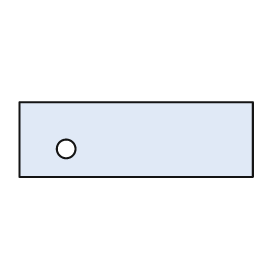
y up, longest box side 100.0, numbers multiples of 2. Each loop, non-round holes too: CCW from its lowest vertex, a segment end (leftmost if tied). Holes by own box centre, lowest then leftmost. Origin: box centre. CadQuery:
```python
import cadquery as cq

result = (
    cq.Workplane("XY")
    .moveTo(-50.0, -16.0)
    .lineTo(50.0, -16.0)
    .lineTo(50.0, 16.0)
    .lineTo(-50.0, 16.0)
    .close()
    .moveTo(-30.0, -4.0)
    .circle(4.0)
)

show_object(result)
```